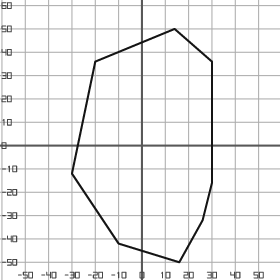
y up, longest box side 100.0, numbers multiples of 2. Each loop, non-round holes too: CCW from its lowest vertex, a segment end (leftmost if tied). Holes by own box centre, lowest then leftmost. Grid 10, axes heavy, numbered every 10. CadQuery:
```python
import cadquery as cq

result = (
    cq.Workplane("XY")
    .moveTo(16.0, -50.0)
    .lineTo(26.0, -32.0)
    .lineTo(30.0, -16.0)
    .lineTo(30.0, 36.0)
    .lineTo(14.0, 50.0)
    .lineTo(-20.0, 36.0)
    .lineTo(-30.0, -12.0)
    .lineTo(-10.0, -42.0)
    .close()
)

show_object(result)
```